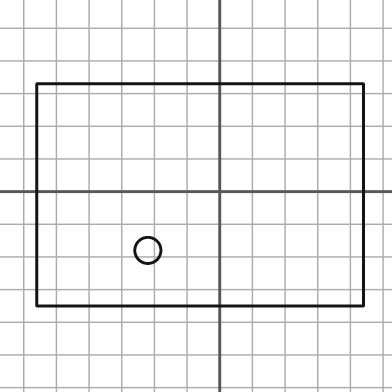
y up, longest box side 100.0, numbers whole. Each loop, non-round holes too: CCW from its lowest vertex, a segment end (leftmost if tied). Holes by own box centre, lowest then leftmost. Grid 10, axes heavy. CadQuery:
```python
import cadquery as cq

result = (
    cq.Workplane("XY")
    .moveTo(-56.0, -35.0)
    .lineTo(44.0, -35.0)
    .lineTo(44.0, 33.0)
    .lineTo(-56.0, 33.0)
    .close()
    .moveTo(-22.0, -18.0)
    .circle(4.0)
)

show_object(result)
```